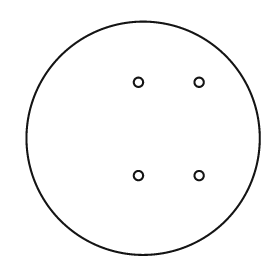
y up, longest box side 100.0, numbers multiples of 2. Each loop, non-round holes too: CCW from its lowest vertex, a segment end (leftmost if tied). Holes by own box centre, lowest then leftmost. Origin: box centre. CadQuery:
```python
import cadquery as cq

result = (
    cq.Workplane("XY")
    .moveTo(0.0, 0.0)
    .circle(50.0)
    .moveTo(-2.0, -16.0)
    .circle(2.0)
    .moveTo(24.0, -16.0)
    .circle(2.0)
    .moveTo(-2.0, 24.0)
    .circle(2.0)
    .moveTo(24.0, 24.0)
    .circle(2.0)
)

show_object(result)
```